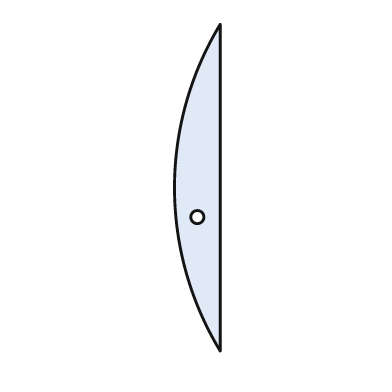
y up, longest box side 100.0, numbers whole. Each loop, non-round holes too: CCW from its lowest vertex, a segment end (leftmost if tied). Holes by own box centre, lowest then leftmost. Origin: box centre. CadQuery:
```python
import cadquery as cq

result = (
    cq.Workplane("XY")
    .moveTo(7.0, -50.0)
    .lineTo(7.0, 50.0)
    .threePointArc((-7.0, 0.0), (7.0, -50.0))
    .close()
    .moveTo(0.0, -9.0)
    .circle(2.0)
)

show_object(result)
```